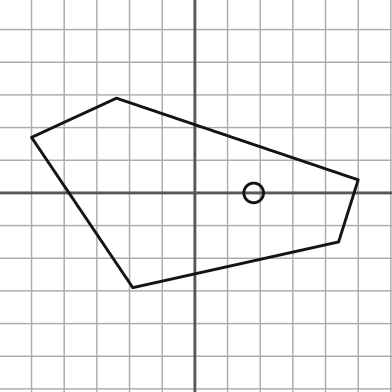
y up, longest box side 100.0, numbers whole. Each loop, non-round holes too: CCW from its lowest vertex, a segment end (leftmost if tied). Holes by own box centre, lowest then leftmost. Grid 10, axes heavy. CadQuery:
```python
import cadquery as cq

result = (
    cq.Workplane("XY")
    .moveTo(-19.0, -29.0)
    .lineTo(44.0, -15.0)
    .lineTo(50.0, 4.0)
    .lineTo(-24.0, 29.0)
    .lineTo(-50.0, 17.0)
    .close()
    .moveTo(18.0, 0.0)
    .circle(3.0)
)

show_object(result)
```